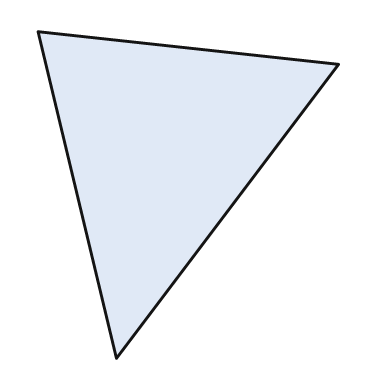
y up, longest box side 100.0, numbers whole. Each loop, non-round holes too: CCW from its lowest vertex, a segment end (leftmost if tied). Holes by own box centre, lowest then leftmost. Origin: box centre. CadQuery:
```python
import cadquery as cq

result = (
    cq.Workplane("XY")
    .moveTo(-22.0, -50.0)
    .lineTo(46.0, 40.0)
    .lineTo(-46.0, 50.0)
    .close()
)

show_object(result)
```